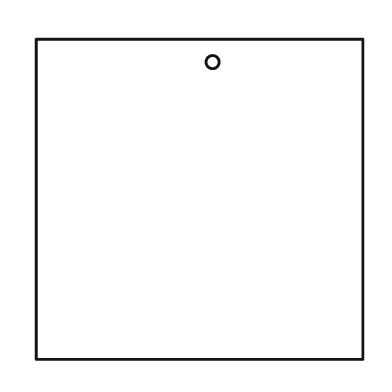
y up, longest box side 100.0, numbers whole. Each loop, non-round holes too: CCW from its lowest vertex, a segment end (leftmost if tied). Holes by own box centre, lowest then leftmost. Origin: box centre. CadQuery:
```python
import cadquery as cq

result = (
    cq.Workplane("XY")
    .moveTo(-50.0, -49.0)
    .lineTo(50.0, -49.0)
    .lineTo(50.0, 49.0)
    .lineTo(-50.0, 49.0)
    .close()
    .moveTo(4.0, 42.0)
    .circle(2.0)
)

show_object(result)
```